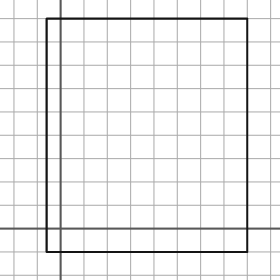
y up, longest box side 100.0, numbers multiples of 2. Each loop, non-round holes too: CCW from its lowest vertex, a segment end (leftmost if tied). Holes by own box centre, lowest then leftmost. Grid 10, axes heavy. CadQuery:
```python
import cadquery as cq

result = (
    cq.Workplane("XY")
    .moveTo(-6.0, -10.0)
    .lineTo(80.0, -10.0)
    .lineTo(80.0, 90.0)
    .lineTo(-6.0, 90.0)
    .close()
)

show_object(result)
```